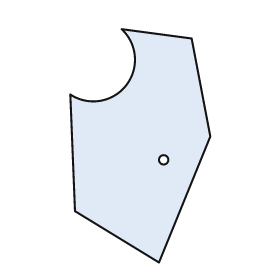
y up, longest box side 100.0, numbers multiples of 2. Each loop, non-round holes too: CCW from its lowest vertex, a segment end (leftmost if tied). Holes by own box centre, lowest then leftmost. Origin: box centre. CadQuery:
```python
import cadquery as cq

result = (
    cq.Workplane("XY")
    .moveTo(8.0, -50.0)
    .lineTo(30.0, 4.0)
    .lineTo(22.0, 46.0)
    .lineTo(-8.0, 50.0)
    .threePointArc((-6.0, 26.0), (-30.0, 22.0))
    .lineTo(-28.0, -28.0)
    .close()
    .moveTo(10.0, -6.0)
    .circle(2.0)
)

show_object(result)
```